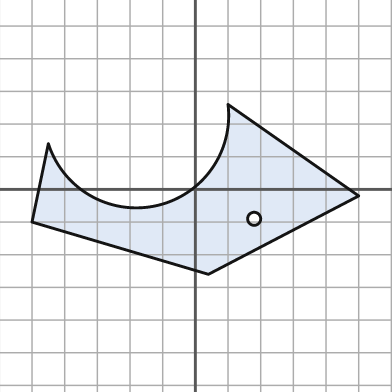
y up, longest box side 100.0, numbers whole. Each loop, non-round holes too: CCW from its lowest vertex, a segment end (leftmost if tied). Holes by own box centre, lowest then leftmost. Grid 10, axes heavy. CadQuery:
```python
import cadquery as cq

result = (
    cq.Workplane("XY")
    .moveTo(4.0, -26.0)
    .lineTo(50.0, -2.0)
    .lineTo(10.0, 26.0)
    .threePointArc((-12.0, -5.0), (-45.0, 14.0))
    .lineTo(-50.0, -10.0)
    .close()
    .moveTo(18.0, -9.0)
    .circle(2.0)
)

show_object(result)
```